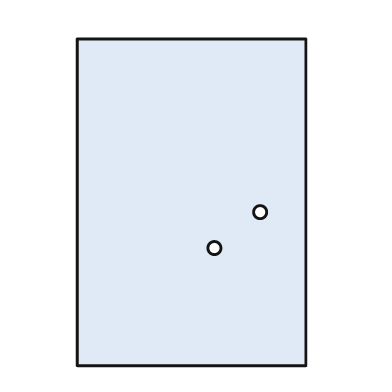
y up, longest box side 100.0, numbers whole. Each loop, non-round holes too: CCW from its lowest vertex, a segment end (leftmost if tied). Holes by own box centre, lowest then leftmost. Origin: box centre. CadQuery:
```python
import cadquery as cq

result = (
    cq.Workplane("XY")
    .moveTo(-35.0, -50.0)
    .lineTo(35.0, -50.0)
    .lineTo(35.0, 50.0)
    .lineTo(-35.0, 50.0)
    .close()
    .moveTo(7.0, -14.0)
    .circle(2.0)
    .moveTo(21.0, -3.0)
    .circle(2.0)
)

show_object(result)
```